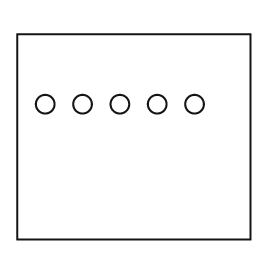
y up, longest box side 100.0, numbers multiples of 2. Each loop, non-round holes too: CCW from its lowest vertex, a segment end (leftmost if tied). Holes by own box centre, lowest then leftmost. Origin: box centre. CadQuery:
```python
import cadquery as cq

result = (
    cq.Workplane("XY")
    .moveTo(-50.0, -44.0)
    .lineTo(50.0, -44.0)
    .lineTo(50.0, 44.0)
    .lineTo(-50.0, 44.0)
    .close()
    .moveTo(-38.0, 14.0)
    .circle(4.0)
    .moveTo(-22.0, 14.0)
    .circle(4.0)
    .moveTo(-6.0, 14.0)
    .circle(4.0)
    .moveTo(10.0, 14.0)
    .circle(4.0)
    .moveTo(26.0, 14.0)
    .circle(4.0)
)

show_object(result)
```